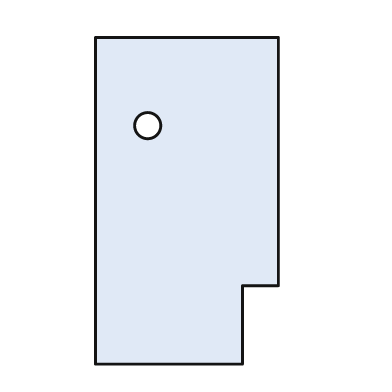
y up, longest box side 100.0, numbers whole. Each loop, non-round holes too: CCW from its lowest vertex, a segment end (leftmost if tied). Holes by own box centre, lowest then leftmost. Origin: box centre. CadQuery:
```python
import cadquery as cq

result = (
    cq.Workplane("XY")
    .moveTo(-28.0, -50.0)
    .lineTo(17.0, -50.0)
    .lineTo(17.0, -26.0)
    .lineTo(28.0, -26.0)
    .lineTo(28.0, 50.0)
    .lineTo(-28.0, 50.0)
    .close()
    .moveTo(-12.0, 23.0)
    .circle(4.0)
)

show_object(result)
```